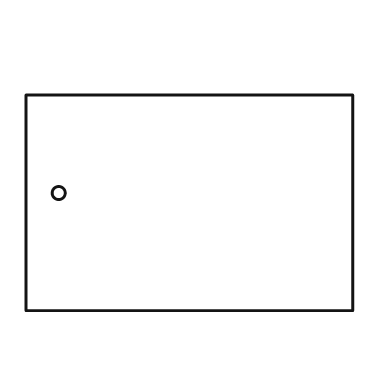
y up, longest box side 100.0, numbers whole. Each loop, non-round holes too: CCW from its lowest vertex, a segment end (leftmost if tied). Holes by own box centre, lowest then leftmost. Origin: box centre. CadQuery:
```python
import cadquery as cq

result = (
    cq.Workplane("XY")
    .moveTo(-50.0, -33.0)
    .lineTo(50.0, -33.0)
    .lineTo(50.0, 33.0)
    .lineTo(-50.0, 33.0)
    .close()
    .moveTo(-40.0, 3.0)
    .circle(2.0)
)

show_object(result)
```